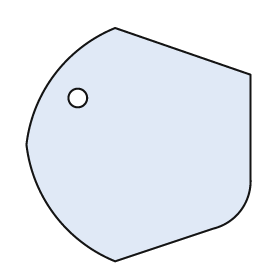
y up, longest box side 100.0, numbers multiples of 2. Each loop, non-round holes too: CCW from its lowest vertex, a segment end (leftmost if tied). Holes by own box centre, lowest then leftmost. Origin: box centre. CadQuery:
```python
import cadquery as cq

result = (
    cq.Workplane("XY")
    .moveTo(-10.0, -50.0)
    .lineTo(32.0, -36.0)
    .threePointArc((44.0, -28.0), (48.0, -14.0))
    .lineTo(48.0, 30.0)
    .lineTo(-10.0, 50.0)
    .threePointArc((-36.0, 30.0), (-48.0, 0.0))
    .threePointArc((-36.0, -30.0), (-10.0, -50.0))
    .close()
    .moveTo(-26.0, 20.0)
    .circle(4.0)
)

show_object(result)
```